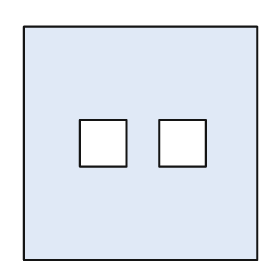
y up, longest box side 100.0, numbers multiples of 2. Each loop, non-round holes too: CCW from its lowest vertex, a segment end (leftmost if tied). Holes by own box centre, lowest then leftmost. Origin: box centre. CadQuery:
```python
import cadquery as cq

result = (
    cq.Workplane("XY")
    .moveTo(-50.0, -50.0)
    .lineTo(50.0, -50.0)
    .lineTo(50.0, 50.0)
    .lineTo(-50.0, 50.0)
    .close()
    .moveTo(-26.0, -10.0)
    .lineTo(-6.0, -10.0)
    .lineTo(-6.0, 10.0)
    .lineTo(-26.0, 10.0)
    .close()
    .moveTo(8.0, -10.0)
    .lineTo(28.0, -10.0)
    .lineTo(28.0, 10.0)
    .lineTo(8.0, 10.0)
    .close()
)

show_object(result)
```